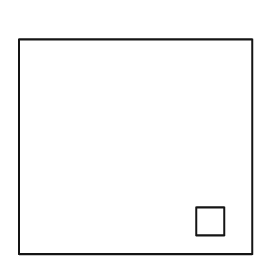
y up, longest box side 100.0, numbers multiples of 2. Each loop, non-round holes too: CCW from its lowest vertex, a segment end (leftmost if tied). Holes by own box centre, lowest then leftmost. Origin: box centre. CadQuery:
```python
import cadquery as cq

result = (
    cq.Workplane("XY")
    .moveTo(-50.0, -46.0)
    .lineTo(50.0, -46.0)
    .lineTo(50.0, 46.0)
    .lineTo(-50.0, 46.0)
    .close()
    .moveTo(26.0, -38.0)
    .lineTo(38.0, -38.0)
    .lineTo(38.0, -26.0)
    .lineTo(26.0, -26.0)
    .close()
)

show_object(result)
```